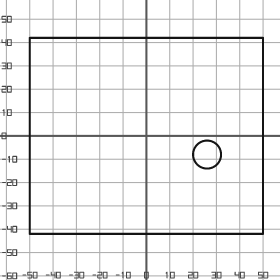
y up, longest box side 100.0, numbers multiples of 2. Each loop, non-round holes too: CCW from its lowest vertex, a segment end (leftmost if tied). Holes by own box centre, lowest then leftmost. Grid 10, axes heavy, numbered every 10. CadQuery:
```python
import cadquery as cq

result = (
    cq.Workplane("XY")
    .moveTo(-50.0, -42.0)
    .lineTo(50.0, -42.0)
    .lineTo(50.0, 42.0)
    .lineTo(-50.0, 42.0)
    .close()
    .moveTo(26.0, -8.0)
    .circle(6.0)
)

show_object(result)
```